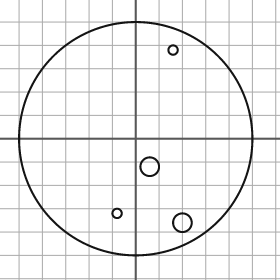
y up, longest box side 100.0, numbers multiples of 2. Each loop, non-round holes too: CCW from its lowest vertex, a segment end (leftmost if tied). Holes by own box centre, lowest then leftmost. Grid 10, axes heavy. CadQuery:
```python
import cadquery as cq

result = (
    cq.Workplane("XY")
    .moveTo(0.0, 0.0)
    .circle(50.0)
    .moveTo(20.0, -36.0)
    .circle(4.0)
    .moveTo(-8.0, -32.0)
    .circle(2.0)
    .moveTo(6.0, -12.0)
    .circle(4.0)
    .moveTo(16.0, 38.0)
    .circle(2.0)
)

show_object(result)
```